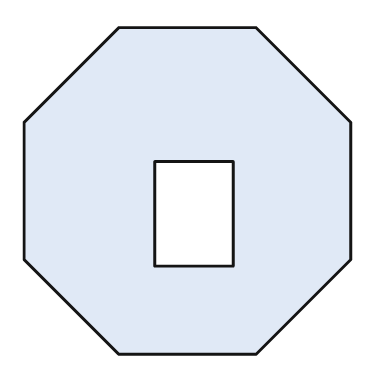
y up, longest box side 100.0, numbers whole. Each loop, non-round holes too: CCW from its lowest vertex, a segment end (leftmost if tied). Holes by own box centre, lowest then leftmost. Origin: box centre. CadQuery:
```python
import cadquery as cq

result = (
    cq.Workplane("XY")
    .moveTo(-21.0, -50.0)
    .lineTo(21.0, -50.0)
    .lineTo(50.0, -21.0)
    .lineTo(50.0, 21.0)
    .lineTo(21.0, 50.0)
    .lineTo(-21.0, 50.0)
    .lineTo(-50.0, 21.0)
    .lineTo(-50.0, -21.0)
    .close()
    .moveTo(-10.0, -23.0)
    .lineTo(14.0, -23.0)
    .lineTo(14.0, 9.0)
    .lineTo(-10.0, 9.0)
    .close()
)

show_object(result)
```